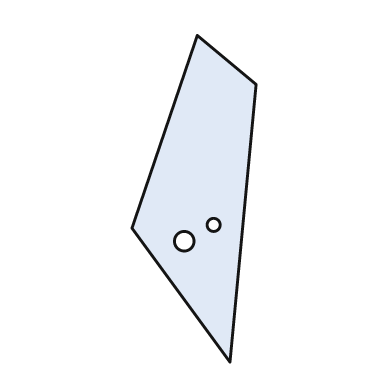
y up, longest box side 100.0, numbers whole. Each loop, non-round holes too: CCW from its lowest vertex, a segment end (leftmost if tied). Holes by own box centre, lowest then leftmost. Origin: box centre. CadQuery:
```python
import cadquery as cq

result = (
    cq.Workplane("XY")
    .moveTo(11.0, -50.0)
    .lineTo(19.0, 35.0)
    .lineTo(1.0, 50.0)
    .lineTo(-19.0, -9.0)
    .close()
    .moveTo(-3.0, -13.0)
    .circle(3.0)
    .moveTo(6.0, -8.0)
    .circle(2.0)
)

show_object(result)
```